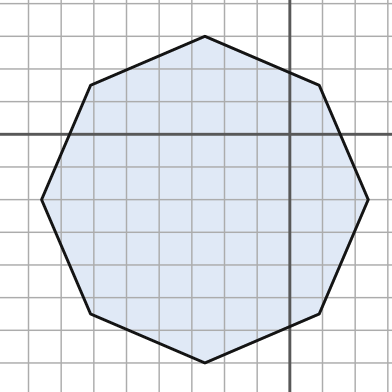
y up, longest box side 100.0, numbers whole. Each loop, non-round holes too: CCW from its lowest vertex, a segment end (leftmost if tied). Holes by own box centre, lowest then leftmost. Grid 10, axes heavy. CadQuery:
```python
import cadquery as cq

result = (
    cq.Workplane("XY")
    .moveTo(-26.0, -70.0)
    .lineTo(9.0, -55.0)
    .lineTo(24.0, -20.0)
    .lineTo(9.0, 15.0)
    .lineTo(-26.0, 30.0)
    .lineTo(-61.0, 15.0)
    .lineTo(-76.0, -20.0)
    .lineTo(-61.0, -55.0)
    .close()
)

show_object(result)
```